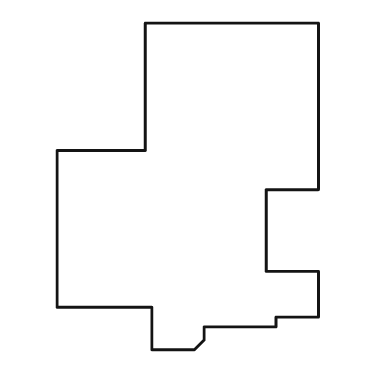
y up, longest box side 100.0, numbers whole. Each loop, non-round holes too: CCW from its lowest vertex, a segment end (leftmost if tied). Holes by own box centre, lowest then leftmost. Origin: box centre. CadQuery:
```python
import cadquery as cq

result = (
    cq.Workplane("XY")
    .moveTo(-11.0, -50.0)
    .lineTo(2.0, -50.0)
    .lineTo(5.0, -47.0)
    .lineTo(5.0, -43.0)
    .lineTo(27.0, -43.0)
    .lineTo(27.0, -40.0)
    .lineTo(40.0, -40.0)
    .lineTo(40.0, -26.0)
    .lineTo(24.0, -26.0)
    .lineTo(24.0, -1.0)
    .lineTo(40.0, -1.0)
    .lineTo(40.0, 50.0)
    .lineTo(-13.0, 50.0)
    .lineTo(-13.0, 11.0)
    .lineTo(-40.0, 11.0)
    .lineTo(-40.0, -37.0)
    .lineTo(-11.0, -37.0)
    .close()
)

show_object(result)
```